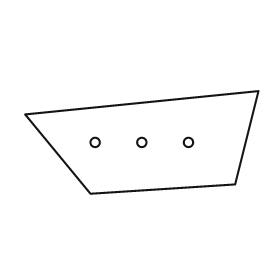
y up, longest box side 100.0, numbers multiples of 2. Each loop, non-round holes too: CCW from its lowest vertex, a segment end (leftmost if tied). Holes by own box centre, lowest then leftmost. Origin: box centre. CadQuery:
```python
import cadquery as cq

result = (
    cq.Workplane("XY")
    .moveTo(-22.0, -22.0)
    .lineTo(40.0, -18.0)
    .lineTo(50.0, 22.0)
    .lineTo(-50.0, 12.0)
    .close()
    .moveTo(-20.0, 0.0)
    .circle(2.0)
    .moveTo(0.0, 0.0)
    .circle(2.0)
    .moveTo(20.0, 0.0)
    .circle(2.0)
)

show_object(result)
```